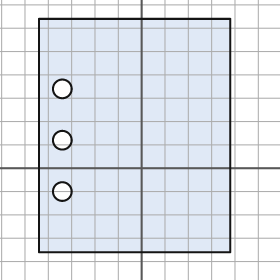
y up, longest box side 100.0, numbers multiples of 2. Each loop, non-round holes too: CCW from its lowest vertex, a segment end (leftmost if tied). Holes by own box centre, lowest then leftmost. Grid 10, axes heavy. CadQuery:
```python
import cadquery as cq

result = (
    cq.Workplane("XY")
    .moveTo(-44.0, -36.0)
    .lineTo(38.0, -36.0)
    .lineTo(38.0, 64.0)
    .lineTo(-44.0, 64.0)
    .close()
    .moveTo(-34.0, -10.0)
    .circle(4.0)
    .moveTo(-34.0, 12.0)
    .circle(4.0)
    .moveTo(-34.0, 34.0)
    .circle(4.0)
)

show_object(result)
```